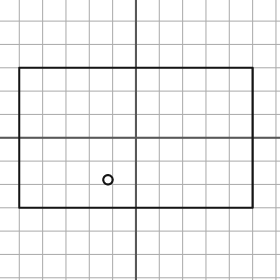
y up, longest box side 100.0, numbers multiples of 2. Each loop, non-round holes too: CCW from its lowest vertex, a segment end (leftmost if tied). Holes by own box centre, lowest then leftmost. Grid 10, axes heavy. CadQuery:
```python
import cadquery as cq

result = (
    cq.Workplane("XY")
    .moveTo(-50.0, -30.0)
    .lineTo(50.0, -30.0)
    .lineTo(50.0, 30.0)
    .lineTo(-50.0, 30.0)
    .close()
    .moveTo(-12.0, -18.0)
    .circle(2.0)
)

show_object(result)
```